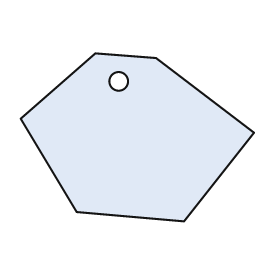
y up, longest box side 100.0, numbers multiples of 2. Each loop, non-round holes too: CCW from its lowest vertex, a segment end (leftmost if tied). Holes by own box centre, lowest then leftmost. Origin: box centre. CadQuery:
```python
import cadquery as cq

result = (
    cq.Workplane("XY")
    .moveTo(20.0, -36.0)
    .lineTo(50.0, 2.0)
    .lineTo(8.0, 34.0)
    .lineTo(-18.0, 36.0)
    .lineTo(-50.0, 8.0)
    .lineTo(-26.0, -32.0)
    .close()
    .moveTo(-8.0, 24.0)
    .circle(4.0)
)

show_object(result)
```